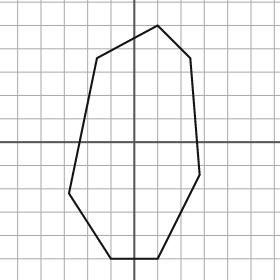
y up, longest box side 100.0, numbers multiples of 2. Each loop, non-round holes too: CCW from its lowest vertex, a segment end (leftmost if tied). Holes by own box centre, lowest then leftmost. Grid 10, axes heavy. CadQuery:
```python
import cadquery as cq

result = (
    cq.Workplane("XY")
    .moveTo(-10.0, -50.0)
    .lineTo(10.0, -50.0)
    .lineTo(28.0, -14.0)
    .lineTo(24.0, 36.0)
    .lineTo(10.0, 50.0)
    .lineTo(-16.0, 36.0)
    .lineTo(-28.0, -22.0)
    .close()
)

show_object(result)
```